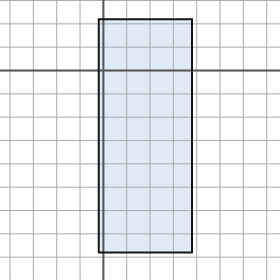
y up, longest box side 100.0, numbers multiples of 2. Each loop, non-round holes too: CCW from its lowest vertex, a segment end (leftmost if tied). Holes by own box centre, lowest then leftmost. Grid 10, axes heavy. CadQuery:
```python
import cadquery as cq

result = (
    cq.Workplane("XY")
    .moveTo(-2.0, -78.0)
    .lineTo(38.0, -78.0)
    .lineTo(38.0, 22.0)
    .lineTo(-2.0, 22.0)
    .close()
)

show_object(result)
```